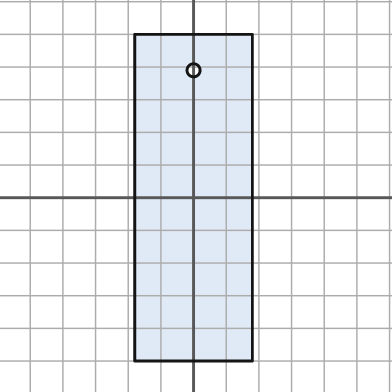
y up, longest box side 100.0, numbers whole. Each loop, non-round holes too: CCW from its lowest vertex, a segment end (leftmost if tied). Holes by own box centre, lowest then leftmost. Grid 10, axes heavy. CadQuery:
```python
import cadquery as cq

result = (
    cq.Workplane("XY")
    .moveTo(-18.0, -50.0)
    .lineTo(18.0, -50.0)
    .lineTo(18.0, 50.0)
    .lineTo(-18.0, 50.0)
    .close()
    .moveTo(0.0, 39.0)
    .circle(2.0)
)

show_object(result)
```